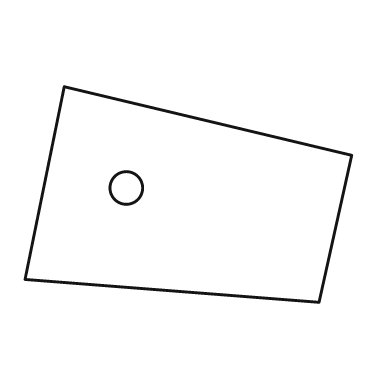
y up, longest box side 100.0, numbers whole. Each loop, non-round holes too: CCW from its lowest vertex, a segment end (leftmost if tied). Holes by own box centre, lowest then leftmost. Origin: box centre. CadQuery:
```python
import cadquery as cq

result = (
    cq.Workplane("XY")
    .moveTo(40.0, -33.0)
    .lineTo(50.0, 12.0)
    .lineTo(-38.0, 33.0)
    .lineTo(-50.0, -26.0)
    .close()
    .moveTo(-19.0, 2.0)
    .circle(5.0)
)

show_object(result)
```